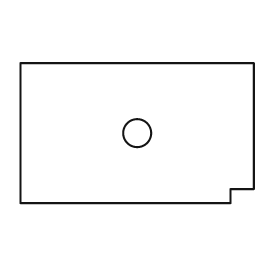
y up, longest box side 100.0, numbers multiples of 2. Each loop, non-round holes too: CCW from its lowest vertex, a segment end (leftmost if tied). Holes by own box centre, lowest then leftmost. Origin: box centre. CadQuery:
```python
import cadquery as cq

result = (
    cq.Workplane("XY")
    .moveTo(-50.0, -30.0)
    .lineTo(40.0, -30.0)
    .lineTo(40.0, -24.0)
    .lineTo(50.0, -24.0)
    .lineTo(50.0, 30.0)
    .lineTo(-50.0, 30.0)
    .close()
    .moveTo(0.0, 0.0)
    .circle(6.0)
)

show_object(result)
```